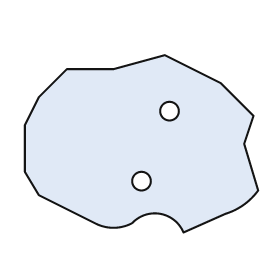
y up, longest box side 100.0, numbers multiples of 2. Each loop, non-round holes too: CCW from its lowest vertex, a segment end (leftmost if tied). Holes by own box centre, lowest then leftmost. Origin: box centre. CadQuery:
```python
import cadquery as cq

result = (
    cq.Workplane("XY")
    .moveTo(18.0, -38.0)
    .lineTo(36.0, -30.0)
    .threePointArc((44.0, -26.0), (50.0, -20.0))
    .lineTo(44.0, 0.0)
    .lineTo(48.0, 12.0)
    .lineTo(34.0, 26.0)
    .lineTo(10.0, 38.0)
    .lineTo(-12.0, 32.0)
    .lineTo(-32.0, 32.0)
    .lineTo(-44.0, 20.0)
    .lineTo(-50.0, 8.0)
    .lineTo(-50.0, -12.0)
    .lineTo(-44.0, -22.0)
    .lineTo(-20.0, -34.0)
    .threePointArc((-12.0, -36.0), (-4.0, -34.0))
    .threePointArc((8.0, -30.0), (18.0, -38.0))
    .close()
    .moveTo(0.0, -16.0)
    .circle(4.0)
    .moveTo(12.0, 14.0)
    .circle(4.0)
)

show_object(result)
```